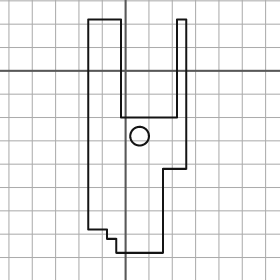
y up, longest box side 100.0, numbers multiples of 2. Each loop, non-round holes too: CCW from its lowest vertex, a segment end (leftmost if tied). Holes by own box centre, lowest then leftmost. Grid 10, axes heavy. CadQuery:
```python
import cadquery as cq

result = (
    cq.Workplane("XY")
    .moveTo(-4.0, -78.0)
    .lineTo(16.0, -78.0)
    .lineTo(16.0, -42.0)
    .lineTo(26.0, -42.0)
    .lineTo(26.0, 22.0)
    .lineTo(22.0, 22.0)
    .lineTo(22.0, -20.0)
    .lineTo(-2.0, -20.0)
    .lineTo(-2.0, 22.0)
    .lineTo(-16.0, 22.0)
    .lineTo(-16.0, -68.0)
    .lineTo(-8.0, -68.0)
    .lineTo(-8.0, -72.0)
    .lineTo(-4.0, -72.0)
    .close()
    .moveTo(6.0, -28.0)
    .circle(4.0)
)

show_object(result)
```